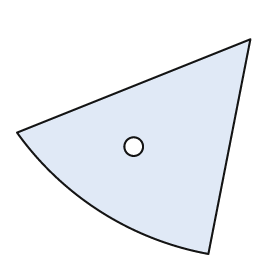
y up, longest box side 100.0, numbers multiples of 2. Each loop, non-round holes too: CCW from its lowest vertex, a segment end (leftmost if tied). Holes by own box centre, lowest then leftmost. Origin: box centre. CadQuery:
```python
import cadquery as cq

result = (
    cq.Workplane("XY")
    .moveTo(32.0, -46.0)
    .lineTo(50.0, 46.0)
    .lineTo(-50.0, 6.0)
    .threePointArc((-14.0, -28.0), (32.0, -46.0))
    .close()
    .moveTo(0.0, 0.0)
    .circle(4.0)
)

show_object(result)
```